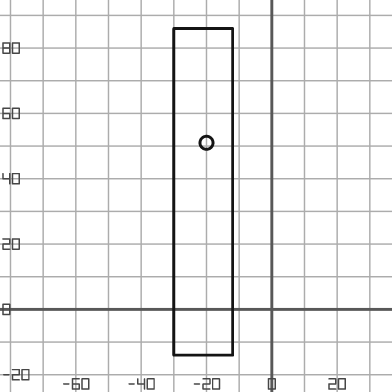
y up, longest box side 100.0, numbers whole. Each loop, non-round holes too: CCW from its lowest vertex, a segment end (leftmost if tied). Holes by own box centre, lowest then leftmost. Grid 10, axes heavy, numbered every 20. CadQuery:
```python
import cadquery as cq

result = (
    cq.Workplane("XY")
    .moveTo(-30.0, -14.0)
    .lineTo(-12.0, -14.0)
    .lineTo(-12.0, 86.0)
    .lineTo(-30.0, 86.0)
    .close()
    .moveTo(-20.0, 51.0)
    .circle(2.0)
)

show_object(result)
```